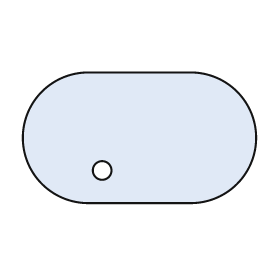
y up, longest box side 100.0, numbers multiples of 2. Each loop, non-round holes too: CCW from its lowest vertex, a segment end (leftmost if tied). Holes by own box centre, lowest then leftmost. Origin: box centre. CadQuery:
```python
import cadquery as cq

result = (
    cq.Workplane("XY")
    .moveTo(-22.0, -28.0)
    .lineTo(22.0, -28.0)
    .threePointArc((50.0, 0.0), (22.0, 28.0))
    .lineTo(-22.0, 28.0)
    .threePointArc((-50.0, 0.0), (-22.0, -28.0))
    .close()
    .moveTo(-16.0, -14.0)
    .circle(4.0)
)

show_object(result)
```